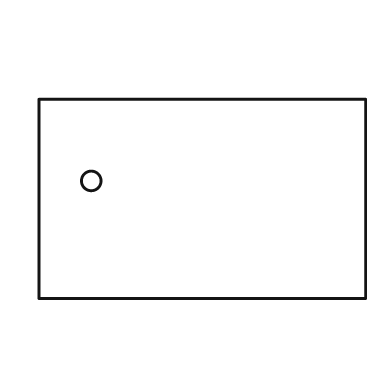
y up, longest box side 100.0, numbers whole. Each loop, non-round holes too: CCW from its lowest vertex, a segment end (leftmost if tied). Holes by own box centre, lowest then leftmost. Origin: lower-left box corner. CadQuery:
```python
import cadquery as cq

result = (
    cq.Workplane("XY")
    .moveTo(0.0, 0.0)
    .lineTo(100.0, 0.0)
    .lineTo(100.0, 61.0)
    .lineTo(0.0, 61.0)
    .close()
    .moveTo(16.0, 36.0)
    .circle(3.0)
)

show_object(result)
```